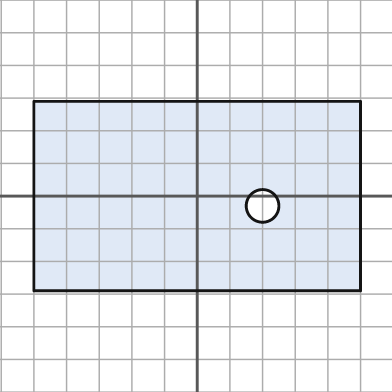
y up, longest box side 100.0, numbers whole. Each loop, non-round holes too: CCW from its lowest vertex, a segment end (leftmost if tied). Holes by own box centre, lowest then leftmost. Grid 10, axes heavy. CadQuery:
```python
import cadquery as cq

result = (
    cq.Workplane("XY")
    .moveTo(-50.0, -29.0)
    .lineTo(50.0, -29.0)
    .lineTo(50.0, 29.0)
    .lineTo(-50.0, 29.0)
    .close()
    .moveTo(20.0, -3.0)
    .circle(5.0)
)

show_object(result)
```